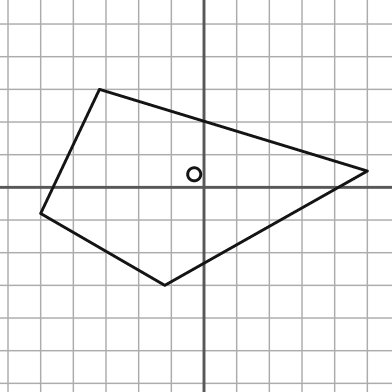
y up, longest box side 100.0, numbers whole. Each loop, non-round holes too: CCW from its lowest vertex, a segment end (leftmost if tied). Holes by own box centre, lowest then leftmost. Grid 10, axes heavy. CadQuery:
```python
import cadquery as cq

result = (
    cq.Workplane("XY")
    .moveTo(-12.0, -30.0)
    .lineTo(50.0, 5.0)
    .lineTo(-32.0, 30.0)
    .lineTo(-50.0, -8.0)
    .close()
    .moveTo(-3.0, 4.0)
    .circle(2.0)
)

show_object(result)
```